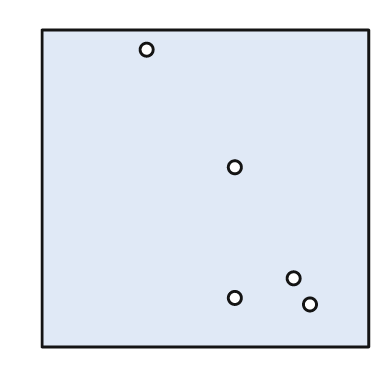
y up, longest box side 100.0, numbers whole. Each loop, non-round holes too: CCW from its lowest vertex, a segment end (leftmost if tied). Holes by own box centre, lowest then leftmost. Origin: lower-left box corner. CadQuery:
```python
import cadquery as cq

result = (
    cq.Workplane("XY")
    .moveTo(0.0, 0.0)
    .lineTo(100.0, 0.0)
    .lineTo(100.0, 97.0)
    .lineTo(0.0, 97.0)
    .close()
    .moveTo(82.0, 13.0)
    .circle(2.0)
    .moveTo(59.0, 15.0)
    .circle(2.0)
    .moveTo(77.0, 21.0)
    .circle(2.0)
    .moveTo(59.0, 55.0)
    .circle(2.0)
    .moveTo(32.0, 91.0)
    .circle(2.0)
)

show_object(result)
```